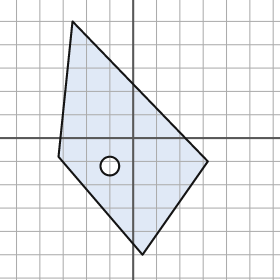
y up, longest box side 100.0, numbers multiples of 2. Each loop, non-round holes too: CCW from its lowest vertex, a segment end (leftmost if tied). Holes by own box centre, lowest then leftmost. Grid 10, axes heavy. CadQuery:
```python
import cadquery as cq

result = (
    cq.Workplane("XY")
    .moveTo(4.0, -50.0)
    .lineTo(32.0, -10.0)
    .lineTo(-26.0, 50.0)
    .lineTo(-32.0, -8.0)
    .close()
    .moveTo(-10.0, -12.0)
    .circle(4.0)
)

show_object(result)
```